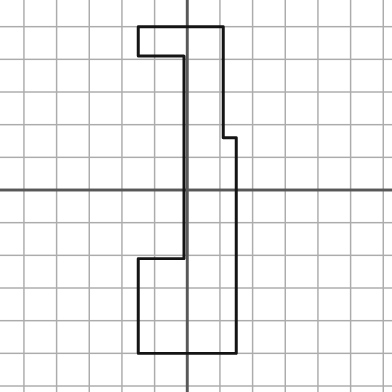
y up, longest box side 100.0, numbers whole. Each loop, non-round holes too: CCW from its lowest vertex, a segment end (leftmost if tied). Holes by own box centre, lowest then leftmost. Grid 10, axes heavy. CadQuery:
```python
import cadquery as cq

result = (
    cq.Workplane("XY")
    .moveTo(-15.0, -50.0)
    .lineTo(15.0, -50.0)
    .lineTo(15.0, 16.0)
    .lineTo(11.0, 16.0)
    .lineTo(11.0, 50.0)
    .lineTo(-15.0, 50.0)
    .lineTo(-15.0, 41.0)
    .lineTo(-1.0, 41.0)
    .lineTo(-1.0, -21.0)
    .lineTo(-15.0, -21.0)
    .close()
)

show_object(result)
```